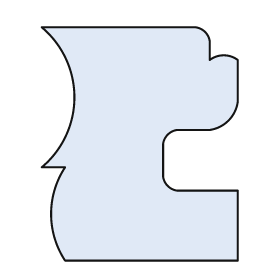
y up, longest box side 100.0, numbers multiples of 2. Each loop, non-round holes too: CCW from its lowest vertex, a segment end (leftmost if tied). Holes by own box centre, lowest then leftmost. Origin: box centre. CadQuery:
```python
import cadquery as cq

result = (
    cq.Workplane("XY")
    .moveTo(-32.0, -50.0)
    .lineTo(42.0, -50.0)
    .lineTo(42.0, -20.0)
    .lineTo(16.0, -20.0)
    .threePointArc((12.0, -18.0), (10.0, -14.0))
    .lineTo(10.0, 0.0)
    .threePointArc((12.0, 4.0), (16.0, 6.0))
    .lineTo(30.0, 6.0)
    .threePointArc((38.0, 10.0), (42.0, 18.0))
    .lineTo(42.0, 36.0)
    .threePointArc((36.0, 38.0), (30.0, 36.0))
    .lineTo(30.0, 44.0)
    .threePointArc((28.0, 48.0), (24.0, 50.0))
    .lineTo(-42.0, 50.0)
    .threePointArc((-28.0, 20.0), (-42.0, -10.0))
    .lineTo(-32.0, -10.0)
    .threePointArc((-38.0, -30.0), (-32.0, -50.0))
    .close()
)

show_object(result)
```